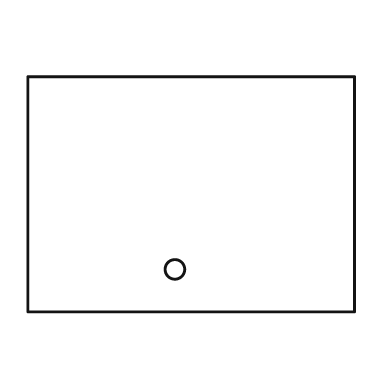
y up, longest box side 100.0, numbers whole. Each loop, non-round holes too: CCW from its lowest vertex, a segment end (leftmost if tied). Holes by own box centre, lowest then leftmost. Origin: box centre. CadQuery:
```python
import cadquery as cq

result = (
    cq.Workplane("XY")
    .moveTo(-50.0, -36.0)
    .lineTo(50.0, -36.0)
    .lineTo(50.0, 36.0)
    .lineTo(-50.0, 36.0)
    .close()
    .moveTo(-5.0, -23.0)
    .circle(3.0)
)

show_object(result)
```